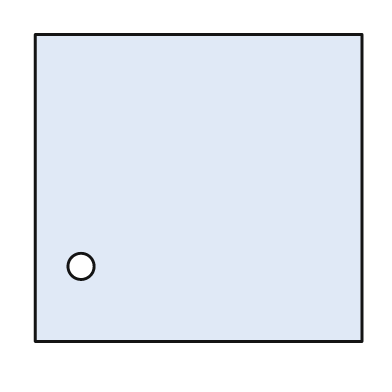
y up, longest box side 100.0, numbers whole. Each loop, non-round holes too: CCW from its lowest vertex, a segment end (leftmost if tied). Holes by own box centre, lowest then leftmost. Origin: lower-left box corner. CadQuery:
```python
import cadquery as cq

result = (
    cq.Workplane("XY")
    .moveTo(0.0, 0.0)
    .lineTo(100.0, 0.0)
    .lineTo(100.0, 94.0)
    .lineTo(0.0, 94.0)
    .close()
    .moveTo(14.0, 23.0)
    .circle(4.0)
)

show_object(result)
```